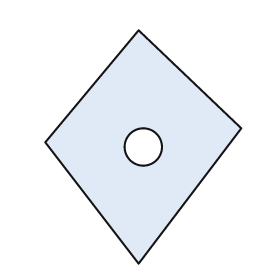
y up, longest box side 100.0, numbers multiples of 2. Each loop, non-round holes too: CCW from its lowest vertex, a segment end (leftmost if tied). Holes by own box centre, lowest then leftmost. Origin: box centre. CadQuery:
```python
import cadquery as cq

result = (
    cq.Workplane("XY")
    .moveTo(-2.0, -50.0)
    .lineTo(42.0, 8.0)
    .lineTo(-2.0, 50.0)
    .lineTo(-42.0, 2.0)
    .close()
    .moveTo(0.0, 0.0)
    .circle(8.0)
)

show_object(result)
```